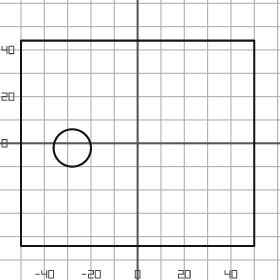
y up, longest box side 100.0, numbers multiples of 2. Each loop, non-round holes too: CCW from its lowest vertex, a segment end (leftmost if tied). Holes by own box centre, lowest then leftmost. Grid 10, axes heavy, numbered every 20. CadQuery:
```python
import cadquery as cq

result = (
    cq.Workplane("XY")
    .moveTo(-50.0, -44.0)
    .lineTo(50.0, -44.0)
    .lineTo(50.0, 44.0)
    .lineTo(-50.0, 44.0)
    .close()
    .moveTo(-28.0, -2.0)
    .circle(8.0)
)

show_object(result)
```